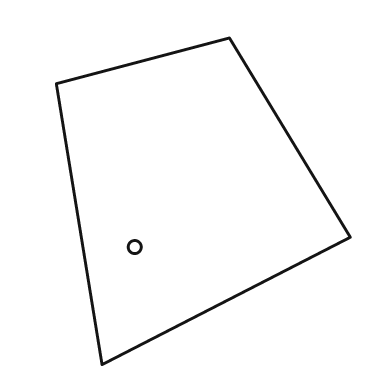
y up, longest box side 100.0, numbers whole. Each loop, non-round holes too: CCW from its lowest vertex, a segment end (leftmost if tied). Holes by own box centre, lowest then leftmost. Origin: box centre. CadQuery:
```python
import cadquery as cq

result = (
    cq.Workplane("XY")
    .moveTo(-31.0, -50.0)
    .lineTo(45.0, -11.0)
    .lineTo(8.0, 50.0)
    .lineTo(-45.0, 36.0)
    .close()
    .moveTo(-21.0, -14.0)
    .circle(2.0)
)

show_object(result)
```